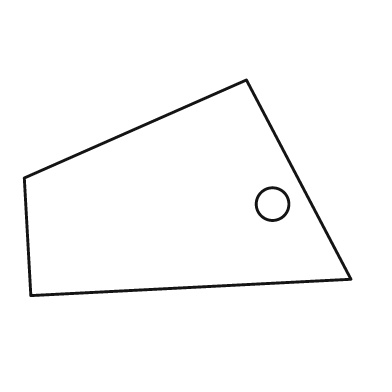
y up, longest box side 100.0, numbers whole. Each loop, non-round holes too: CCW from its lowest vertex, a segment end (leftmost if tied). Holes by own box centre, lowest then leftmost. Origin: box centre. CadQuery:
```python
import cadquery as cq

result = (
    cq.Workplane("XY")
    .moveTo(-48.0, -33.0)
    .lineTo(50.0, -28.0)
    .lineTo(18.0, 33.0)
    .lineTo(-50.0, 3.0)
    .close()
    .moveTo(26.0, -5.0)
    .circle(5.0)
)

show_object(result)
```